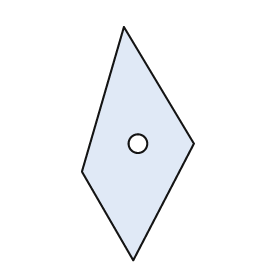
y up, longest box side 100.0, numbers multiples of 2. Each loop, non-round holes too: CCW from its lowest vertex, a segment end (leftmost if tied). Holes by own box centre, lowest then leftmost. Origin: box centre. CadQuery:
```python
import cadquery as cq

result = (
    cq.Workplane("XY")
    .moveTo(-2.0, -50.0)
    .lineTo(24.0, 0.0)
    .lineTo(-6.0, 50.0)
    .lineTo(-24.0, -12.0)
    .close()
    .moveTo(0.0, 0.0)
    .circle(4.0)
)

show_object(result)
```